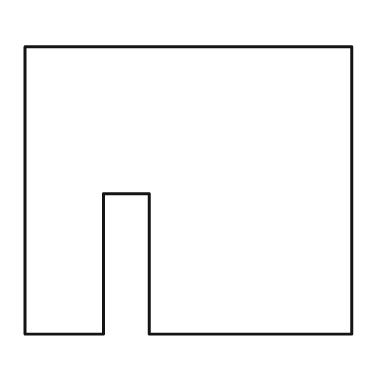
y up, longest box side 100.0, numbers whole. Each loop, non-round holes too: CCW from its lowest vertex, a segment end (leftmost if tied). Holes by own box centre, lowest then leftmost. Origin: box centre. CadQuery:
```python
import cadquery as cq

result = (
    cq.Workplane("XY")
    .moveTo(-50.0, -44.0)
    .lineTo(-26.0, -44.0)
    .lineTo(-26.0, -1.0)
    .lineTo(-12.0, -1.0)
    .lineTo(-12.0, -44.0)
    .lineTo(50.0, -44.0)
    .lineTo(50.0, 44.0)
    .lineTo(-50.0, 44.0)
    .close()
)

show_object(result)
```